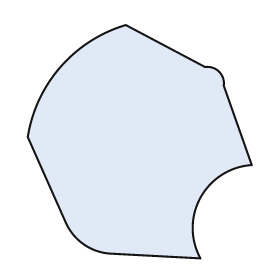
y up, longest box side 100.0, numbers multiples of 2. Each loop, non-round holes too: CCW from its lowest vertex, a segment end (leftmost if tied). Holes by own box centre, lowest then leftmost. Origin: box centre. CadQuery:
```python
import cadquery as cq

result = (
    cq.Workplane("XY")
    .moveTo(26.0, -50.0)
    .threePointArc((26.0, -24.0), (48.0, -10.0))
    .lineTo(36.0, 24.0)
    .threePointArc((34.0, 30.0), (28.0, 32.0))
    .lineTo(-6.0, 50.0)
    .threePointArc((-34.0, 32.0), (-48.0, 2.0))
    .lineTo(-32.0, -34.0)
    .threePointArc((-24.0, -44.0), (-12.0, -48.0))
    .close()
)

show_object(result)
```